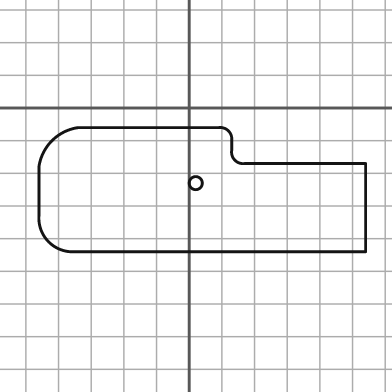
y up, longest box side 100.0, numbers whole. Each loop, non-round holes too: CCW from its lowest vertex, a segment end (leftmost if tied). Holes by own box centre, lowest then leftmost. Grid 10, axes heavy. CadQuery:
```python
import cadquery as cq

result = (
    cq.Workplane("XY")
    .moveTo(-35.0, -44.0)
    .lineTo(54.0, -44.0)
    .lineTo(54.0, -17.0)
    .lineTo(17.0, -17.0)
    .threePointArc((14.0, -16.0), (13.0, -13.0))
    .lineTo(13.0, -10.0)
    .threePointArc((12.0, -7.0), (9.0, -6.0))
    .lineTo(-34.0, -6.0)
    .threePointArc((-42.0, -10.0), (-46.0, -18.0))
    .lineTo(-46.0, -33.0)
    .threePointArc((-43.0, -41.0), (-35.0, -44.0))
    .close()
    .moveTo(2.0, -23.0)
    .circle(2.0)
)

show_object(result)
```